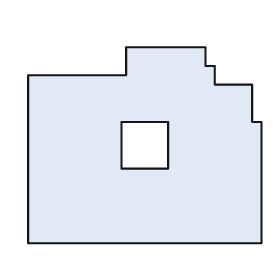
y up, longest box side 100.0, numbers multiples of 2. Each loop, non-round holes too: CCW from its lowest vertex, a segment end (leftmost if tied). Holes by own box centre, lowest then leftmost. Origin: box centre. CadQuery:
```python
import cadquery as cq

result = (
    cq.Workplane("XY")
    .moveTo(-50.0, -42.0)
    .lineTo(50.0, -42.0)
    .lineTo(50.0, 10.0)
    .lineTo(46.0, 10.0)
    .lineTo(46.0, 26.0)
    .lineTo(30.0, 26.0)
    .lineTo(30.0, 34.0)
    .lineTo(26.0, 34.0)
    .lineTo(26.0, 42.0)
    .lineTo(-8.0, 42.0)
    .lineTo(-8.0, 30.0)
    .lineTo(-50.0, 30.0)
    .close()
    .moveTo(-10.0, -10.0)
    .lineTo(10.0, -10.0)
    .lineTo(10.0, 10.0)
    .lineTo(-10.0, 10.0)
    .close()
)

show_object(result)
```